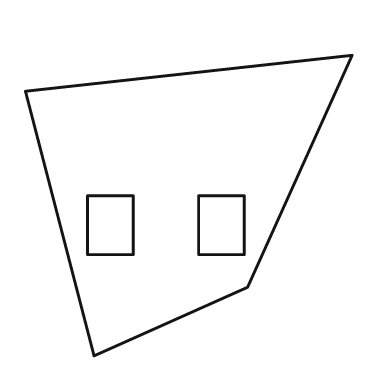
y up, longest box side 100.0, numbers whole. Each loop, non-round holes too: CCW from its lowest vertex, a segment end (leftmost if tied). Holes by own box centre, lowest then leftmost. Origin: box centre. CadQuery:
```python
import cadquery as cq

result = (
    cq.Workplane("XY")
    .moveTo(-29.0, -46.0)
    .lineTo(18.0, -25.0)
    .lineTo(50.0, 46.0)
    .lineTo(-50.0, 35.0)
    .close()
    .moveTo(-31.0, -15.0)
    .lineTo(-17.0, -15.0)
    .lineTo(-17.0, 3.0)
    .lineTo(-31.0, 3.0)
    .close()
    .moveTo(3.0, -15.0)
    .lineTo(17.0, -15.0)
    .lineTo(17.0, 3.0)
    .lineTo(3.0, 3.0)
    .close()
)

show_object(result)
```